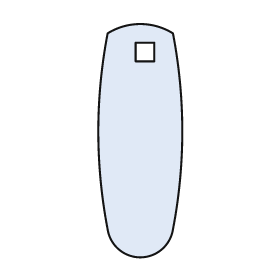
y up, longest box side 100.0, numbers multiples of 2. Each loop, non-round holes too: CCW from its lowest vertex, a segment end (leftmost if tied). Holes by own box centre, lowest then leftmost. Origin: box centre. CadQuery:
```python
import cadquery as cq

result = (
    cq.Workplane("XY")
    .moveTo(-14.0, -38.0)
    .threePointArc((0.0, -50.0), (14.0, -38.0))
    .threePointArc((18.0, 4.0), (14.0, 46.0))
    .threePointArc((0.0, 50.0), (-14.0, 46.0))
    .threePointArc((-18.0, 4.0), (-14.0, -38.0))
    .close()
    .moveTo(-2.0, 34.0)
    .lineTo(6.0, 34.0)
    .lineTo(6.0, 42.0)
    .lineTo(-2.0, 42.0)
    .close()
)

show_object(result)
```